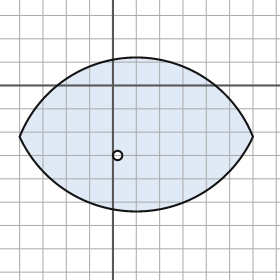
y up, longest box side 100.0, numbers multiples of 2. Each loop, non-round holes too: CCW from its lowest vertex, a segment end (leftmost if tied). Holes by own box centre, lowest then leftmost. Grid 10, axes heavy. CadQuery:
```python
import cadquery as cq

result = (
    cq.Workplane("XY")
    .moveTo(-40.0, -22.0)
    .threePointArc((10.0, -54.0), (60.0, -22.0))
    .threePointArc((10.0, 12.0), (-40.0, -22.0))
    .close()
    .moveTo(2.0, -30.0)
    .circle(2.0)
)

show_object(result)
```